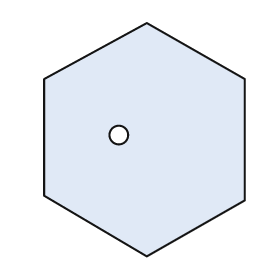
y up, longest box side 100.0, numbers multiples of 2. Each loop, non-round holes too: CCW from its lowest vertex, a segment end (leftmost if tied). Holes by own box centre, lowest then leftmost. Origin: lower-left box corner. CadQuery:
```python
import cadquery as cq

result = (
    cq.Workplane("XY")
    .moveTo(44.0, 0.0)
    .lineTo(86.0, 24.0)
    .lineTo(86.0, 76.0)
    .lineTo(44.0, 100.0)
    .lineTo(0.0, 76.0)
    .lineTo(0.0, 26.0)
    .close()
    .moveTo(32.0, 52.0)
    .circle(4.0)
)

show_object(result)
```